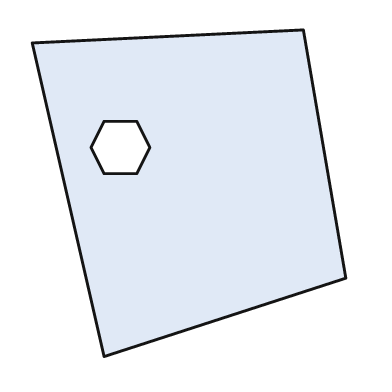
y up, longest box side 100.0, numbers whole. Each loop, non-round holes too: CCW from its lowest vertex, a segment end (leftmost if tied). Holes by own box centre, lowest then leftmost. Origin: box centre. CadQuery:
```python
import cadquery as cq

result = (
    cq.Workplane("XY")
    .moveTo(-26.0, -50.0)
    .lineTo(48.0, -26.0)
    .lineTo(35.0, 50.0)
    .lineTo(-48.0, 46.0)
    .close()
    .moveTo(-26.0, 6.0)
    .lineTo(-16.0, 6.0)
    .lineTo(-12.0, 14.0)
    .lineTo(-16.0, 22.0)
    .lineTo(-26.0, 22.0)
    .lineTo(-30.0, 14.0)
    .close()
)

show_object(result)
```